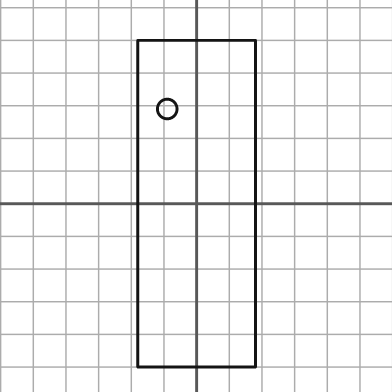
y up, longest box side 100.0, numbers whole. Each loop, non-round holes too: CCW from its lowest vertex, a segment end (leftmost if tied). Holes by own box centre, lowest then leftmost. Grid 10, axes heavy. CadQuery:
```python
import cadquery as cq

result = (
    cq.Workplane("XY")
    .moveTo(-18.0, -50.0)
    .lineTo(18.0, -50.0)
    .lineTo(18.0, 50.0)
    .lineTo(-18.0, 50.0)
    .close()
    .moveTo(-9.0, 29.0)
    .circle(3.0)
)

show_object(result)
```